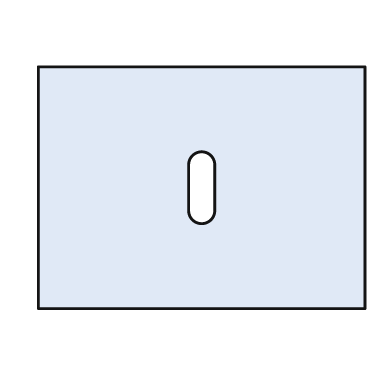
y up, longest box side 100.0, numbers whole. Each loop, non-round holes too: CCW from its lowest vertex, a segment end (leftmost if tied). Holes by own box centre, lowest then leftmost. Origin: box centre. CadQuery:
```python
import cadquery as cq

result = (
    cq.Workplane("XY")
    .moveTo(-50.0, -37.0)
    .lineTo(50.0, -37.0)
    .lineTo(50.0, 37.0)
    .lineTo(-50.0, 37.0)
    .close()
    .moveTo(-4.0, -7.0)
    .threePointArc((0.0, -11.0), (4.0, -7.0))
    .lineTo(4.0, 7.0)
    .threePointArc((0.0, 11.0), (-4.0, 7.0))
    .close()
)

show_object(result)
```